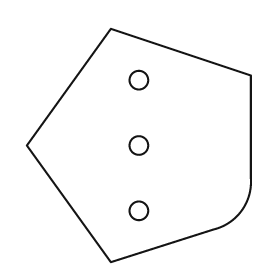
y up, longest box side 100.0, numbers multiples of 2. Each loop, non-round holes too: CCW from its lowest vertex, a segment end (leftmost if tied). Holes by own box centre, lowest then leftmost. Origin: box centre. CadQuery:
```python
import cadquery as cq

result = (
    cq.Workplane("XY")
    .moveTo(-12.0, -50.0)
    .lineTo(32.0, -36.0)
    .threePointArc((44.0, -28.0), (48.0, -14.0))
    .lineTo(48.0, 30.0)
    .lineTo(-12.0, 50.0)
    .lineTo(-48.0, 0.0)
    .close()
    .moveTo(0.0, -28.0)
    .circle(4.0)
    .moveTo(0.0, 0.0)
    .circle(4.0)
    .moveTo(0.0, 28.0)
    .circle(4.0)
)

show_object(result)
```